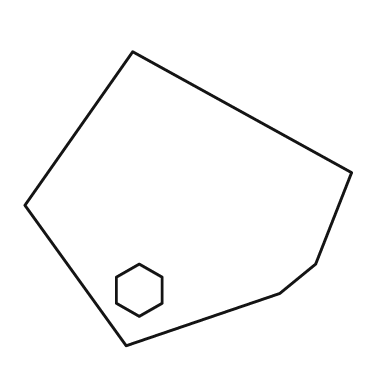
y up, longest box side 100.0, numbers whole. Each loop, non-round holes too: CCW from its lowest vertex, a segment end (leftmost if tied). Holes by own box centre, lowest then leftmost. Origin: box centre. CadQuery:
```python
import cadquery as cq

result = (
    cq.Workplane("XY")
    .moveTo(-19.0, -45.0)
    .lineTo(28.0, -29.0)
    .lineTo(39.0, -20.0)
    .lineTo(50.0, 8.0)
    .lineTo(-17.0, 45.0)
    .lineTo(-50.0, -2.0)
    .close()
    .moveTo(-15.0, -36.0)
    .lineTo(-8.0, -32.0)
    .lineTo(-8.0, -24.0)
    .lineTo(-15.0, -20.0)
    .lineTo(-22.0, -24.0)
    .lineTo(-22.0, -32.0)
    .close()
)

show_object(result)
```